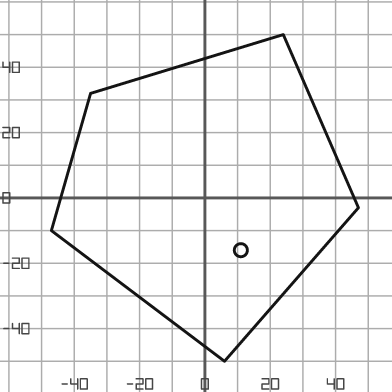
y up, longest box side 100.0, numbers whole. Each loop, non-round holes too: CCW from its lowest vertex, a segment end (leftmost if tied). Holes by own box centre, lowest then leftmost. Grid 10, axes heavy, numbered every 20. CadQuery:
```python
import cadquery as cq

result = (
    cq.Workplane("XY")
    .moveTo(6.0, -50.0)
    .lineTo(47.0, -3.0)
    .lineTo(24.0, 50.0)
    .lineTo(-35.0, 32.0)
    .lineTo(-47.0, -10.0)
    .close()
    .moveTo(11.0, -16.0)
    .circle(2.0)
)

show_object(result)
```